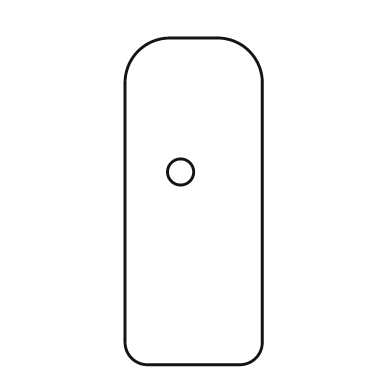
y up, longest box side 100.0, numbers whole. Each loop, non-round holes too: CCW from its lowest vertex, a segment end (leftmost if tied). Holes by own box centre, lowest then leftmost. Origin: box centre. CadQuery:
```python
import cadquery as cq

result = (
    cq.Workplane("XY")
    .moveTo(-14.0, -50.0)
    .lineTo(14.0, -50.0)
    .threePointArc((19.0, -48.0), (21.0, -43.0))
    .lineTo(21.0, 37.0)
    .threePointArc((17.0, 46.0), (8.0, 50.0))
    .lineTo(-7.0, 50.0)
    .threePointArc((-17.0, 46.0), (-21.0, 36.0))
    .lineTo(-21.0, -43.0)
    .threePointArc((-19.0, -48.0), (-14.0, -50.0))
    .close()
    .moveTo(-4.0, 9.0)
    .circle(4.0)
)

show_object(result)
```